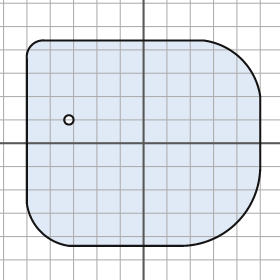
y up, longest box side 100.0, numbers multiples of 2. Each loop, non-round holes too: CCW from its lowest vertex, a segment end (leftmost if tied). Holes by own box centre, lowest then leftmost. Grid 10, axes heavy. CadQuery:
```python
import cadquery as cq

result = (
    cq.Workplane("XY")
    .moveTo(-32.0, -44.0)
    .lineTo(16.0, -44.0)
    .threePointArc((40.0, -34.0), (50.0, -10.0))
    .lineTo(50.0, 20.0)
    .threePointArc((42.0, 36.0), (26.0, 44.0))
    .lineTo(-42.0, 44.0)
    .threePointArc((-48.0, 42.0), (-50.0, 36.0))
    .lineTo(-50.0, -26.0)
    .threePointArc((-44.0, -38.0), (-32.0, -44.0))
    .close()
    .moveTo(-32.0, 10.0)
    .circle(2.0)
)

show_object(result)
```